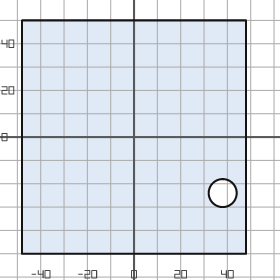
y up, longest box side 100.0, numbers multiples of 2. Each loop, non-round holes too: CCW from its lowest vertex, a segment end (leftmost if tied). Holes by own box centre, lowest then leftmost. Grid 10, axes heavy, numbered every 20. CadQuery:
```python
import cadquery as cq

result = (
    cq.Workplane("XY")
    .moveTo(-48.0, -50.0)
    .lineTo(48.0, -50.0)
    .lineTo(48.0, 50.0)
    .lineTo(-48.0, 50.0)
    .close()
    .moveTo(38.0, -24.0)
    .circle(6.0)
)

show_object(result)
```